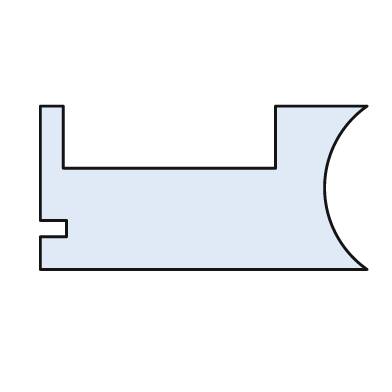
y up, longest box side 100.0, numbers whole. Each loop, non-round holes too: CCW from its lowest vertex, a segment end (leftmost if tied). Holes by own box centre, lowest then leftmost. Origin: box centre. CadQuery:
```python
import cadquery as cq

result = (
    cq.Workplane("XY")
    .moveTo(-50.0, -25.0)
    .lineTo(50.0, -25.0)
    .threePointArc((37.0, 0.0), (50.0, 25.0))
    .lineTo(22.0, 25.0)
    .lineTo(22.0, 6.0)
    .lineTo(-43.0, 6.0)
    .lineTo(-43.0, 25.0)
    .lineTo(-50.0, 25.0)
    .lineTo(-50.0, -10.0)
    .lineTo(-42.0, -10.0)
    .lineTo(-42.0, -15.0)
    .lineTo(-50.0, -15.0)
    .close()
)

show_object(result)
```